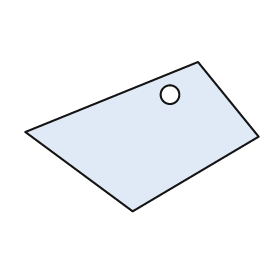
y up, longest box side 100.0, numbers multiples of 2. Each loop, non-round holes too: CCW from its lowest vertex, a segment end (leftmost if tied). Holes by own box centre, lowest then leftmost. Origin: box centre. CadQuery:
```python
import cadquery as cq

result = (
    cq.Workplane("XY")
    .moveTo(-4.0, -32.0)
    .lineTo(50.0, 0.0)
    .lineTo(24.0, 32.0)
    .lineTo(-50.0, 2.0)
    .close()
    .moveTo(12.0, 18.0)
    .circle(4.0)
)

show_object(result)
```